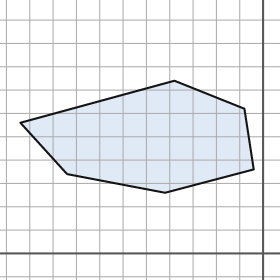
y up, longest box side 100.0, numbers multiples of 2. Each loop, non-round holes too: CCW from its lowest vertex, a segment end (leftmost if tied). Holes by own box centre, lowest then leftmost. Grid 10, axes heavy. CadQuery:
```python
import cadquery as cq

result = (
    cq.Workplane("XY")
    .moveTo(-42.0, 26.0)
    .lineTo(-4.0, 36.0)
    .lineTo(-8.0, 62.0)
    .lineTo(-38.0, 74.0)
    .lineTo(-104.0, 56.0)
    .lineTo(-84.0, 34.0)
    .close()
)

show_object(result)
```